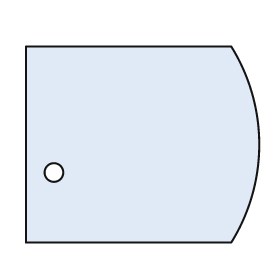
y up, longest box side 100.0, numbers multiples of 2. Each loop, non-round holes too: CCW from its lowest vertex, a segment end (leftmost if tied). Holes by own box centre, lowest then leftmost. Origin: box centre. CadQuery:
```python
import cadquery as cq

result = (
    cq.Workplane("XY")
    .moveTo(-50.0, -42.0)
    .lineTo(38.0, -42.0)
    .threePointArc((50.0, 0.0), (38.0, 42.0))
    .lineTo(-50.0, 42.0)
    .close()
    .moveTo(-38.0, -12.0)
    .circle(4.0)
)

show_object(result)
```